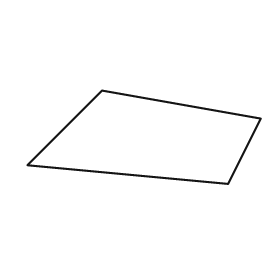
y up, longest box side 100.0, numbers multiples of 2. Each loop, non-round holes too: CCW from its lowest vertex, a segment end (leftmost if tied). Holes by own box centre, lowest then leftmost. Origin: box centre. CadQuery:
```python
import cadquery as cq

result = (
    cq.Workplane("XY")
    .moveTo(36.0, -20.0)
    .lineTo(50.0, 8.0)
    .lineTo(-18.0, 20.0)
    .lineTo(-50.0, -12.0)
    .close()
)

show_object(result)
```